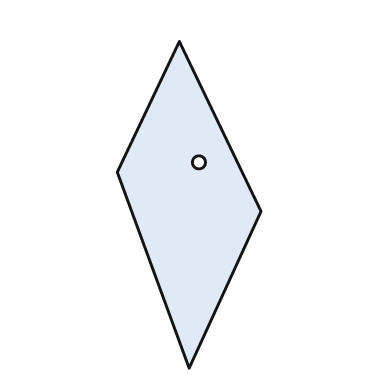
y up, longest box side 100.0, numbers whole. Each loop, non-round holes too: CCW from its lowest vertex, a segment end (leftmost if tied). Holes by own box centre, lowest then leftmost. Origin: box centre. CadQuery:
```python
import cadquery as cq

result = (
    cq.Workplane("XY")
    .moveTo(0.0, -50.0)
    .lineTo(22.0, -2.0)
    .lineTo(-3.0, 50.0)
    .lineTo(-22.0, 10.0)
    .close()
    .moveTo(3.0, 13.0)
    .circle(2.0)
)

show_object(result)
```